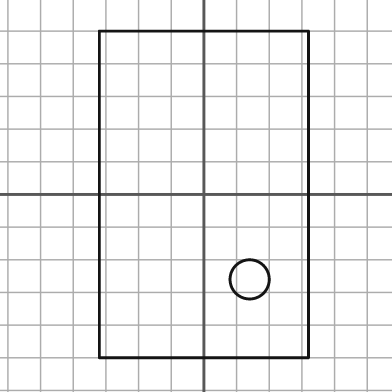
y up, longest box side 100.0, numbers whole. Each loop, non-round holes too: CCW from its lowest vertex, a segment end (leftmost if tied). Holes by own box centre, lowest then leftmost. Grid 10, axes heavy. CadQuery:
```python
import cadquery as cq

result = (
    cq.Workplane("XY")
    .moveTo(-32.0, -50.0)
    .lineTo(32.0, -50.0)
    .lineTo(32.0, 50.0)
    .lineTo(-32.0, 50.0)
    .close()
    .moveTo(14.0, -26.0)
    .circle(6.0)
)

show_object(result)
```